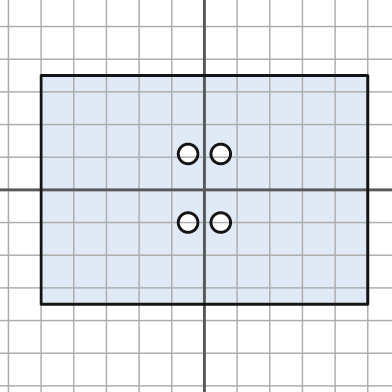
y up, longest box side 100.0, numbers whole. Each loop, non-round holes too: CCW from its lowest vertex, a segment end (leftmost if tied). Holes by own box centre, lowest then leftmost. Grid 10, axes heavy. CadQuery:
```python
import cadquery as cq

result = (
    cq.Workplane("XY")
    .moveTo(-50.0, -35.0)
    .lineTo(50.0, -35.0)
    .lineTo(50.0, 35.0)
    .lineTo(-50.0, 35.0)
    .close()
    .moveTo(-5.0, -10.0)
    .circle(3.0)
    .moveTo(5.0, -10.0)
    .circle(3.0)
    .moveTo(-5.0, 11.0)
    .circle(3.0)
    .moveTo(5.0, 11.0)
    .circle(3.0)
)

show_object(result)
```